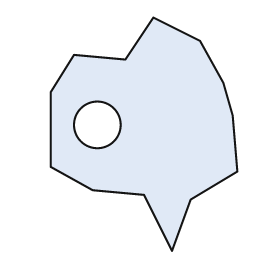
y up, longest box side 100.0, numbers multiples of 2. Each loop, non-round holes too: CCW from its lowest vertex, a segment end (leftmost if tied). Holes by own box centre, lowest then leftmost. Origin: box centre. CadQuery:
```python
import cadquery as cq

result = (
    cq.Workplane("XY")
    .moveTo(12.0, -50.0)
    .lineTo(20.0, -28.0)
    .lineTo(40.0, -16.0)
    .lineTo(38.0, 8.0)
    .lineTo(34.0, 22.0)
    .lineTo(24.0, 40.0)
    .lineTo(4.0, 50.0)
    .lineTo(-8.0, 32.0)
    .lineTo(-30.0, 34.0)
    .lineTo(-40.0, 18.0)
    .lineTo(-40.0, -14.0)
    .lineTo(-22.0, -24.0)
    .lineTo(0.0, -26.0)
    .close()
    .moveTo(-20.0, 4.0)
    .circle(10.0)
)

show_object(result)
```